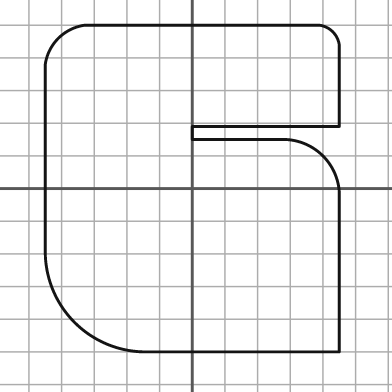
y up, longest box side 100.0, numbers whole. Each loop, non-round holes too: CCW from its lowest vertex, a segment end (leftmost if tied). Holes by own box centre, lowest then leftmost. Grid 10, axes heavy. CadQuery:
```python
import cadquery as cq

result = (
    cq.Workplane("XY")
    .moveTo(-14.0, -50.0)
    .lineTo(45.0, -50.0)
    .lineTo(45.0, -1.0)
    .threePointArc((40.0, 10.0), (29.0, 15.0))
    .lineTo(0.0, 15.0)
    .lineTo(0.0, 19.0)
    .lineTo(45.0, 19.0)
    .lineTo(45.0, 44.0)
    .threePointArc((43.0, 48.0), (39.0, 50.0))
    .lineTo(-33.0, 50.0)
    .threePointArc((-41.0, 46.0), (-45.0, 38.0))
    .lineTo(-45.0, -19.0)
    .threePointArc((-36.0, -41.0), (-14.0, -50.0))
    .close()
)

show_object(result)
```